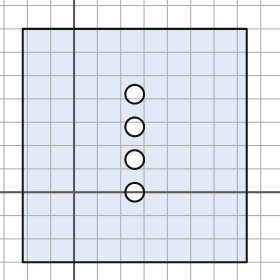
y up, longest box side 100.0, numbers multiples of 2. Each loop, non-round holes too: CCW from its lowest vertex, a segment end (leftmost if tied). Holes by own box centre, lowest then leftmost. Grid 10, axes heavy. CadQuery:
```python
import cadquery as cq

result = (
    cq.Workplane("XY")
    .moveTo(-22.0, -30.0)
    .lineTo(74.0, -30.0)
    .lineTo(74.0, 70.0)
    .lineTo(-22.0, 70.0)
    .close()
    .moveTo(26.0, 0.0)
    .circle(4.0)
    .moveTo(26.0, 14.0)
    .circle(4.0)
    .moveTo(26.0, 28.0)
    .circle(4.0)
    .moveTo(26.0, 42.0)
    .circle(4.0)
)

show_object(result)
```